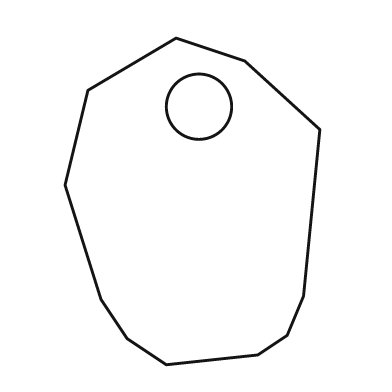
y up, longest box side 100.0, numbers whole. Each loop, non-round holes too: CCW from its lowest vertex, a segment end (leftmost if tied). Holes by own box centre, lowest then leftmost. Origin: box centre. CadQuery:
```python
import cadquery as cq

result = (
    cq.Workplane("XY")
    .moveTo(-8.0, -50.0)
    .lineTo(20.0, -47.0)
    .lineTo(29.0, -41.0)
    .lineTo(34.0, -29.0)
    .lineTo(39.0, 22.0)
    .lineTo(16.0, 43.0)
    .lineTo(-5.0, 50.0)
    .lineTo(-32.0, 34.0)
    .lineTo(-39.0, 5.0)
    .lineTo(-28.0, -30.0)
    .lineTo(-20.0, -42.0)
    .close()
    .moveTo(2.0, 29.0)
    .circle(10.0)
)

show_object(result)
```